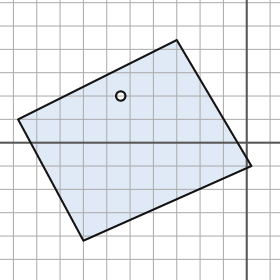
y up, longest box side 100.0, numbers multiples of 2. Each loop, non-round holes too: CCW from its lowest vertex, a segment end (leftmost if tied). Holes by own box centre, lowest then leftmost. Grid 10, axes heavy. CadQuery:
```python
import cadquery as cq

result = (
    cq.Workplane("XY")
    .moveTo(-70.0, -42.0)
    .lineTo(2.0, -10.0)
    .lineTo(-30.0, 44.0)
    .lineTo(-98.0, 10.0)
    .close()
    .moveTo(-54.0, 20.0)
    .circle(2.0)
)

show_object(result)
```